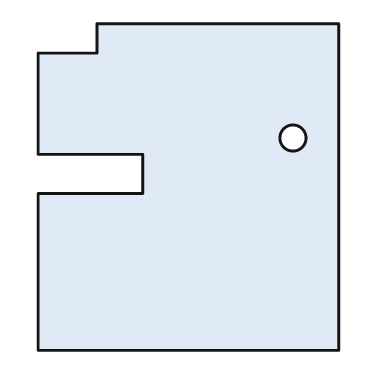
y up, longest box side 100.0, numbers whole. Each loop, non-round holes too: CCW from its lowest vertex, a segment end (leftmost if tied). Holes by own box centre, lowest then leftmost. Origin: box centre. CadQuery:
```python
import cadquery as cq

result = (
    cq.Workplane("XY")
    .moveTo(-46.0, -50.0)
    .lineTo(46.0, -50.0)
    .lineTo(46.0, 50.0)
    .lineTo(-28.0, 50.0)
    .lineTo(-28.0, 41.0)
    .lineTo(-46.0, 41.0)
    .lineTo(-46.0, 10.0)
    .lineTo(-14.0, 10.0)
    .lineTo(-14.0, -2.0)
    .lineTo(-46.0, -2.0)
    .close()
    .moveTo(32.0, 15.0)
    .circle(4.0)
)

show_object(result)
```